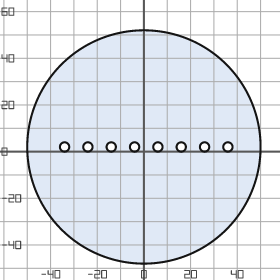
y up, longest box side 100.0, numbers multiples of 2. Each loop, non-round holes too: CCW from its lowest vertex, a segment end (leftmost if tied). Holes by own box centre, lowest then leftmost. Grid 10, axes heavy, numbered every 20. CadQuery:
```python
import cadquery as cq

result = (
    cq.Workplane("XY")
    .moveTo(0.0, 2.0)
    .circle(50.0)
    .moveTo(-34.0, 2.0)
    .circle(2.0)
    .moveTo(-24.0, 2.0)
    .circle(2.0)
    .moveTo(-14.0, 2.0)
    .circle(2.0)
    .moveTo(-4.0, 2.0)
    .circle(2.0)
    .moveTo(6.0, 2.0)
    .circle(2.0)
    .moveTo(16.0, 2.0)
    .circle(2.0)
    .moveTo(26.0, 2.0)
    .circle(2.0)
    .moveTo(36.0, 2.0)
    .circle(2.0)
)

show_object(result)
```